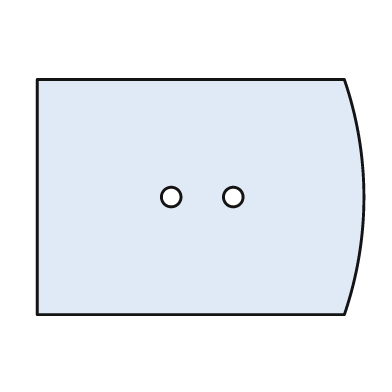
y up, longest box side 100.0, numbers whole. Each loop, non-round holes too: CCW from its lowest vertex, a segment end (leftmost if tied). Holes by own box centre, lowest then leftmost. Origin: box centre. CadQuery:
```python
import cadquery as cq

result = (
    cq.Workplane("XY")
    .moveTo(-50.0, -36.0)
    .lineTo(44.0, -36.0)
    .threePointArc((50.0, 0.0), (44.0, 36.0))
    .lineTo(-50.0, 36.0)
    .close()
    .moveTo(-9.0, 0.0)
    .circle(3.0)
    .moveTo(10.0, 0.0)
    .circle(3.0)
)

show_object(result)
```